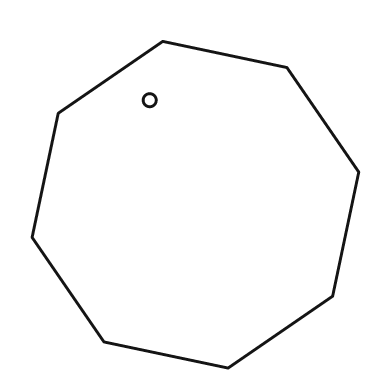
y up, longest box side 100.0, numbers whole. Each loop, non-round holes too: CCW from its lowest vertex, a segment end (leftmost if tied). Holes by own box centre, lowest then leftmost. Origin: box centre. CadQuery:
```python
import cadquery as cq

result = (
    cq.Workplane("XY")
    .moveTo(10.0, -50.0)
    .lineTo(42.0, -28.0)
    .lineTo(50.0, 10.0)
    .lineTo(28.0, 42.0)
    .lineTo(-10.0, 50.0)
    .lineTo(-42.0, 28.0)
    .lineTo(-50.0, -10.0)
    .lineTo(-28.0, -42.0)
    .close()
    .moveTo(-14.0, 32.0)
    .circle(2.0)
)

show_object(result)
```